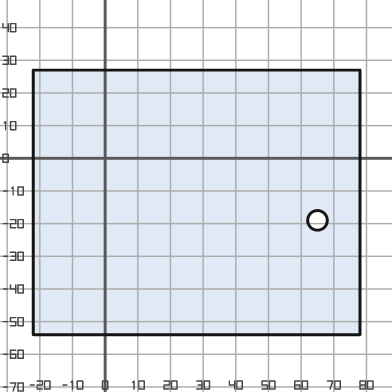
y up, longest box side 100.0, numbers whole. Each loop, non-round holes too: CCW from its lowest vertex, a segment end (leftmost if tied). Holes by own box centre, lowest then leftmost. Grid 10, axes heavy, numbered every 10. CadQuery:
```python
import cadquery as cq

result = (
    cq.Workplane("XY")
    .moveTo(-22.0, -54.0)
    .lineTo(78.0, -54.0)
    .lineTo(78.0, 27.0)
    .lineTo(-22.0, 27.0)
    .close()
    .moveTo(65.0, -19.0)
    .circle(3.0)
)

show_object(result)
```